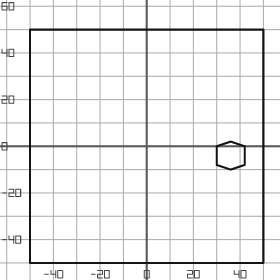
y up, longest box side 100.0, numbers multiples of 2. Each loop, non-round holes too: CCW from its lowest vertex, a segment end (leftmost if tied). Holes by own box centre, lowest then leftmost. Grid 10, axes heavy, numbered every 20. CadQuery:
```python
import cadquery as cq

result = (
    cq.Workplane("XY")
    .moveTo(-50.0, -50.0)
    .lineTo(50.0, -50.0)
    .lineTo(50.0, 50.0)
    .lineTo(-50.0, 50.0)
    .close()
    .moveTo(36.0, -10.0)
    .lineTo(42.0, -8.0)
    .lineTo(42.0, 0.0)
    .lineTo(36.0, 2.0)
    .lineTo(30.0, 0.0)
    .lineTo(30.0, -8.0)
    .close()
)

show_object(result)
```